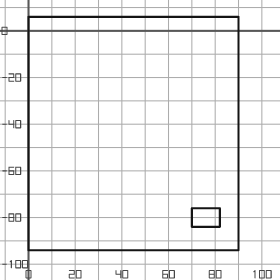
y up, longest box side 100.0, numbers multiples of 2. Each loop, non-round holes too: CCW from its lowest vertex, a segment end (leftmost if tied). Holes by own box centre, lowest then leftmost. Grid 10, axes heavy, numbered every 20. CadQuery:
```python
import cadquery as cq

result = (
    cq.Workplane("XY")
    .moveTo(0.0, -94.0)
    .lineTo(90.0, -94.0)
    .lineTo(90.0, 6.0)
    .lineTo(0.0, 6.0)
    .close()
    .moveTo(70.0, -84.0)
    .lineTo(82.0, -84.0)
    .lineTo(82.0, -76.0)
    .lineTo(70.0, -76.0)
    .close()
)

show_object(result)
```